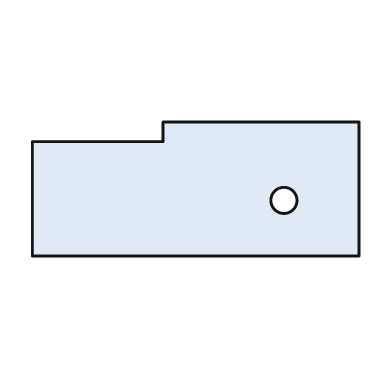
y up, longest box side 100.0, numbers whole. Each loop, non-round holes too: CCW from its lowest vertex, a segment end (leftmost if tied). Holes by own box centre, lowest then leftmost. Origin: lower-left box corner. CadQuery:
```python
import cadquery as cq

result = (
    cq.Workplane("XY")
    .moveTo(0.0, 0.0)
    .lineTo(100.0, 0.0)
    .lineTo(100.0, 41.0)
    .lineTo(40.0, 41.0)
    .lineTo(40.0, 35.0)
    .lineTo(0.0, 35.0)
    .close()
    .moveTo(77.0, 17.0)
    .circle(4.0)
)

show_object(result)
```